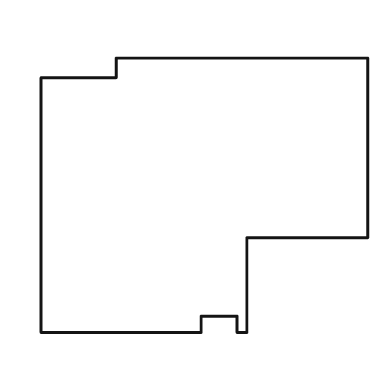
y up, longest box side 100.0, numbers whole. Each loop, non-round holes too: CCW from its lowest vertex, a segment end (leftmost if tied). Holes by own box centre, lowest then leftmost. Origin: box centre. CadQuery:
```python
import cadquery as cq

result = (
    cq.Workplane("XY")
    .moveTo(-50.0, -42.0)
    .lineTo(-1.0, -42.0)
    .lineTo(-1.0, -37.0)
    .lineTo(10.0, -37.0)
    .lineTo(10.0, -42.0)
    .lineTo(13.0, -42.0)
    .lineTo(13.0, -13.0)
    .lineTo(50.0, -13.0)
    .lineTo(50.0, 42.0)
    .lineTo(-27.0, 42.0)
    .lineTo(-27.0, 36.0)
    .lineTo(-50.0, 36.0)
    .close()
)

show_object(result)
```